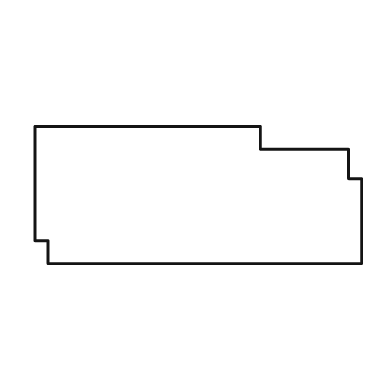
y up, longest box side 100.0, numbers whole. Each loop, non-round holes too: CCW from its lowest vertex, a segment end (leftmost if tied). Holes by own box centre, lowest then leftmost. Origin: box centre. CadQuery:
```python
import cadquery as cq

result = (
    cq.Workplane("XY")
    .moveTo(-46.0, -21.0)
    .lineTo(50.0, -21.0)
    .lineTo(50.0, 5.0)
    .lineTo(46.0, 5.0)
    .lineTo(46.0, 14.0)
    .lineTo(19.0, 14.0)
    .lineTo(19.0, 21.0)
    .lineTo(-50.0, 21.0)
    .lineTo(-50.0, -14.0)
    .lineTo(-46.0, -14.0)
    .close()
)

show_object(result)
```